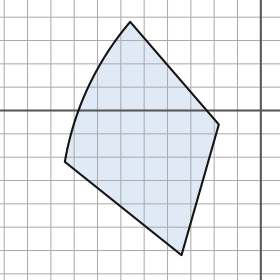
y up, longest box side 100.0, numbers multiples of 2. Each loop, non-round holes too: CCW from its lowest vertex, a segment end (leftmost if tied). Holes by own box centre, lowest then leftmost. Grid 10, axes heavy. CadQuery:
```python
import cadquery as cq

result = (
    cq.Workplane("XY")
    .moveTo(-34.0, -62.0)
    .lineTo(-18.0, -6.0)
    .lineTo(-56.0, 38.0)
    .threePointArc((-74.0, 10.0), (-84.0, -22.0))
    .close()
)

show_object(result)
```